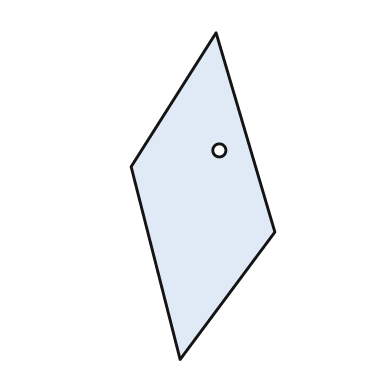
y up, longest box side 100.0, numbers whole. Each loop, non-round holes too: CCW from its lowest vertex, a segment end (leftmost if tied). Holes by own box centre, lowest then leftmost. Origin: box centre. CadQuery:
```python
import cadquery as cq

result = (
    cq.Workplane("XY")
    .moveTo(-7.0, -50.0)
    .lineTo(22.0, -11.0)
    .lineTo(4.0, 50.0)
    .lineTo(-22.0, 9.0)
    .close()
    .moveTo(5.0, 14.0)
    .circle(2.0)
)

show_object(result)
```